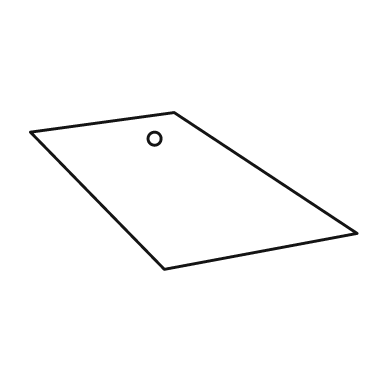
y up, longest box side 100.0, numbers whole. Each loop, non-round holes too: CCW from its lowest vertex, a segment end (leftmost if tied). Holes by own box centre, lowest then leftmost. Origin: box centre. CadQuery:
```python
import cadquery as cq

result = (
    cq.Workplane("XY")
    .moveTo(-9.0, -24.0)
    .lineTo(50.0, -13.0)
    .lineTo(-6.0, 24.0)
    .lineTo(-50.0, 18.0)
    .close()
    .moveTo(-12.0, 16.0)
    .circle(2.0)
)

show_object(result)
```